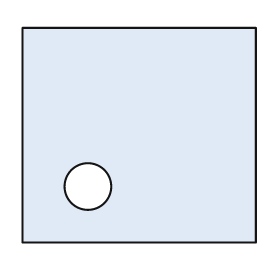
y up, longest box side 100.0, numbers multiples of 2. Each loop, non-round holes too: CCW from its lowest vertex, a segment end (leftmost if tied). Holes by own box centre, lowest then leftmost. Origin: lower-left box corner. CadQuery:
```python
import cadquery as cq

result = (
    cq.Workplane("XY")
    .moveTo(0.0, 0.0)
    .lineTo(100.0, 0.0)
    .lineTo(100.0, 92.0)
    .lineTo(0.0, 92.0)
    .close()
    .moveTo(28.0, 24.0)
    .circle(10.0)
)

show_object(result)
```